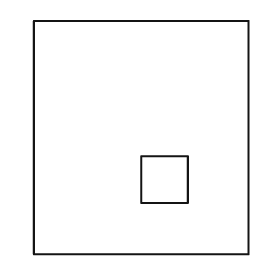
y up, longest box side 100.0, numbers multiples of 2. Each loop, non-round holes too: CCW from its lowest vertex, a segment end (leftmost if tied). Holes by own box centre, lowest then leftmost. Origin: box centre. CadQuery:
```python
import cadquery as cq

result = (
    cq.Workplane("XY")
    .moveTo(-46.0, -50.0)
    .lineTo(46.0, -50.0)
    .lineTo(46.0, 50.0)
    .lineTo(-46.0, 50.0)
    .close()
    .moveTo(0.0, -28.0)
    .lineTo(20.0, -28.0)
    .lineTo(20.0, -8.0)
    .lineTo(0.0, -8.0)
    .close()
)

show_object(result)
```